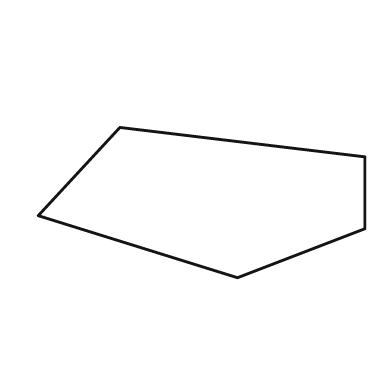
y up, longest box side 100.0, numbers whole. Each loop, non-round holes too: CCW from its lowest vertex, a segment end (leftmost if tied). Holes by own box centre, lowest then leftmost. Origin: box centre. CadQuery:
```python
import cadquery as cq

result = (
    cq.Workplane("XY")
    .moveTo(11.0, -23.0)
    .lineTo(50.0, -8.0)
    .lineTo(50.0, 14.0)
    .lineTo(-25.0, 23.0)
    .lineTo(-50.0, -4.0)
    .close()
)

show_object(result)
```